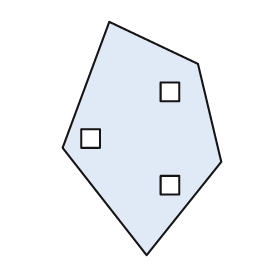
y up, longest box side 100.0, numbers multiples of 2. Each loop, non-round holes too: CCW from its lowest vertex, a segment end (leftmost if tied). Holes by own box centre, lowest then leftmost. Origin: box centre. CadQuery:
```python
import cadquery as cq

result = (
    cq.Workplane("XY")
    .moveTo(2.0, -50.0)
    .lineTo(34.0, -10.0)
    .lineTo(24.0, 32.0)
    .lineTo(-14.0, 50.0)
    .lineTo(-34.0, -4.0)
    .close()
    .moveTo(8.0, -24.0)
    .lineTo(16.0, -24.0)
    .lineTo(16.0, -16.0)
    .lineTo(8.0, -16.0)
    .close()
    .moveTo(-26.0, -4.0)
    .lineTo(-18.0, -4.0)
    .lineTo(-18.0, 4.0)
    .lineTo(-26.0, 4.0)
    .close()
    .moveTo(8.0, 16.0)
    .lineTo(16.0, 16.0)
    .lineTo(16.0, 24.0)
    .lineTo(8.0, 24.0)
    .close()
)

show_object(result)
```